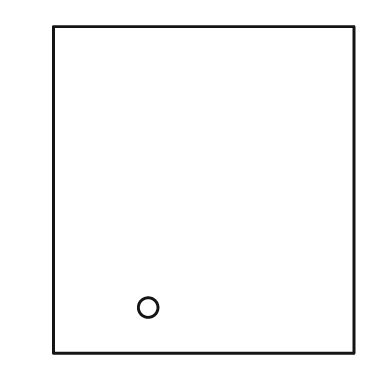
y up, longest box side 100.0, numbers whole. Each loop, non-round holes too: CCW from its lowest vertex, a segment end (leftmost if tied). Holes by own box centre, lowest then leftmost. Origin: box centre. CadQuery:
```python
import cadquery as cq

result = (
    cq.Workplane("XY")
    .moveTo(-46.0, -50.0)
    .lineTo(46.0, -50.0)
    .lineTo(46.0, 50.0)
    .lineTo(-46.0, 50.0)
    .close()
    .moveTo(-17.0, -36.0)
    .circle(3.0)
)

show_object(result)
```